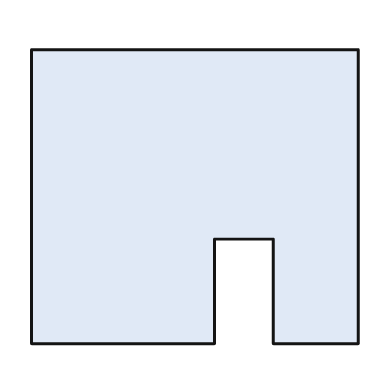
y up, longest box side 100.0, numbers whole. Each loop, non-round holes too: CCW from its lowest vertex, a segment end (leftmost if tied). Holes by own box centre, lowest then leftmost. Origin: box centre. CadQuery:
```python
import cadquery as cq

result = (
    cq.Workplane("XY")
    .moveTo(-50.0, -45.0)
    .lineTo(6.0, -45.0)
    .lineTo(6.0, -13.0)
    .lineTo(24.0, -13.0)
    .lineTo(24.0, -45.0)
    .lineTo(50.0, -45.0)
    .lineTo(50.0, 45.0)
    .lineTo(-50.0, 45.0)
    .close()
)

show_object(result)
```